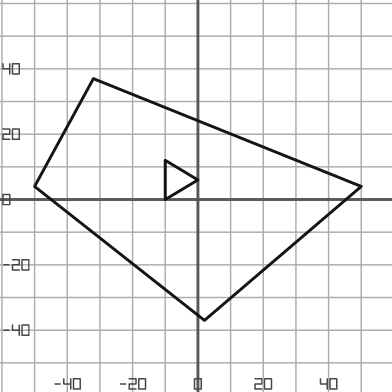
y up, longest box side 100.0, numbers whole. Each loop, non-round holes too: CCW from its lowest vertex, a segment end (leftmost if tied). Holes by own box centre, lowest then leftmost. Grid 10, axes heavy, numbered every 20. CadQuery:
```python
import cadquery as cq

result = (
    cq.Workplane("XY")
    .moveTo(2.0, -37.0)
    .lineTo(50.0, 4.0)
    .lineTo(-32.0, 37.0)
    .lineTo(-50.0, 4.0)
    .close()
    .moveTo(-10.0, 0.0)
    .lineTo(0.0, 6.0)
    .lineTo(-10.0, 12.0)
    .close()
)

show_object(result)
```